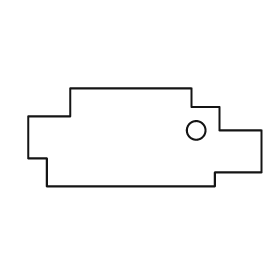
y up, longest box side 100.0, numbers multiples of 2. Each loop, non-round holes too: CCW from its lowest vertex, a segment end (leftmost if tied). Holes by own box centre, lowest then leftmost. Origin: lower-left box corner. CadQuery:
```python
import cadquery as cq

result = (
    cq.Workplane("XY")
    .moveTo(8.0, 0.0)
    .lineTo(80.0, 0.0)
    .lineTo(80.0, 6.0)
    .lineTo(100.0, 6.0)
    .lineTo(100.0, 24.0)
    .lineTo(82.0, 24.0)
    .lineTo(82.0, 34.0)
    .lineTo(70.0, 34.0)
    .lineTo(70.0, 42.0)
    .lineTo(18.0, 42.0)
    .lineTo(18.0, 30.0)
    .lineTo(0.0, 30.0)
    .lineTo(0.0, 12.0)
    .lineTo(8.0, 12.0)
    .close()
    .moveTo(72.0, 24.0)
    .circle(4.0)
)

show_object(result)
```